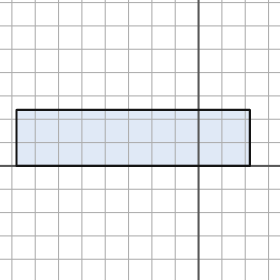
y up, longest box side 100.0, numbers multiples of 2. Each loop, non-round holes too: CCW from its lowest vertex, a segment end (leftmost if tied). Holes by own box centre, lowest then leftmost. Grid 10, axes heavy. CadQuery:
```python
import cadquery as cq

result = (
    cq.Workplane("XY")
    .moveTo(-78.0, 0.0)
    .lineTo(22.0, 0.0)
    .lineTo(22.0, 24.0)
    .lineTo(-78.0, 24.0)
    .close()
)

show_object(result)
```